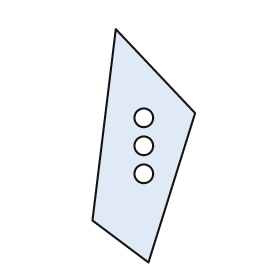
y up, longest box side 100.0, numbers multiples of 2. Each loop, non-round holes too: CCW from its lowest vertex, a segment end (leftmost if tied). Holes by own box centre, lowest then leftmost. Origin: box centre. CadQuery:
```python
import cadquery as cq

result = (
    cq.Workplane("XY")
    .moveTo(2.0, -50.0)
    .lineTo(22.0, 14.0)
    .lineTo(-12.0, 50.0)
    .lineTo(-22.0, -32.0)
    .close()
    .moveTo(0.0, -12.0)
    .circle(4.0)
    .moveTo(0.0, 0.0)
    .circle(4.0)
    .moveTo(0.0, 12.0)
    .circle(4.0)
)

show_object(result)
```